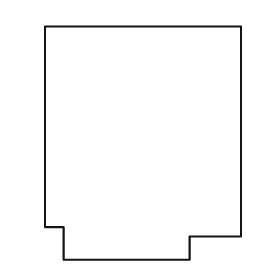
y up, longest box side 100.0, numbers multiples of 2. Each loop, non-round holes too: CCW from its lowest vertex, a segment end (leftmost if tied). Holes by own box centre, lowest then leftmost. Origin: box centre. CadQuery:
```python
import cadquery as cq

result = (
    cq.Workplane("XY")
    .moveTo(-34.0, -50.0)
    .lineTo(20.0, -50.0)
    .lineTo(20.0, -40.0)
    .lineTo(42.0, -40.0)
    .lineTo(42.0, 50.0)
    .lineTo(-42.0, 50.0)
    .lineTo(-42.0, -36.0)
    .lineTo(-34.0, -36.0)
    .close()
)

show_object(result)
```